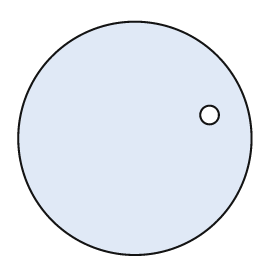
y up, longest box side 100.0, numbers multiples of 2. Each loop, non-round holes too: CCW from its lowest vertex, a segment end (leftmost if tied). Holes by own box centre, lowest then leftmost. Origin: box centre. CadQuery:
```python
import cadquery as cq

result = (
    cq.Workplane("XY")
    .moveTo(0.0, 0.0)
    .circle(50.0)
    .moveTo(32.0, 10.0)
    .circle(4.0)
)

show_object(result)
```